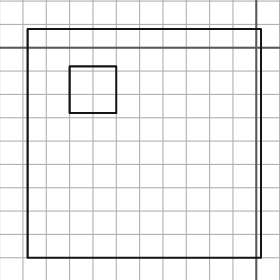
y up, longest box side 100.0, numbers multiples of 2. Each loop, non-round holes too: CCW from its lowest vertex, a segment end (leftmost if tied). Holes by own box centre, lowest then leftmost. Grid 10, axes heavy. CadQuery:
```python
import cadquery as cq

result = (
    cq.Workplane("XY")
    .moveTo(-98.0, -90.0)
    .lineTo(2.0, -90.0)
    .lineTo(2.0, 8.0)
    .lineTo(-98.0, 8.0)
    .close()
    .moveTo(-80.0, -28.0)
    .lineTo(-60.0, -28.0)
    .lineTo(-60.0, -8.0)
    .lineTo(-80.0, -8.0)
    .close()
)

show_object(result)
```